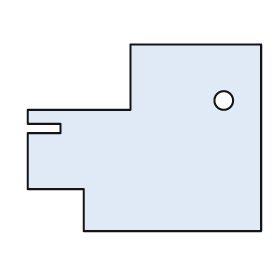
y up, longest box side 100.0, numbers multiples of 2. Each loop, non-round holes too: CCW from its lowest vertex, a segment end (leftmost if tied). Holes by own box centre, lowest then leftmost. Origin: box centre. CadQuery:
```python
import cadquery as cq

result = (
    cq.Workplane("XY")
    .moveTo(-26.0, -40.0)
    .lineTo(50.0, -40.0)
    .lineTo(50.0, 40.0)
    .lineTo(-6.0, 40.0)
    .lineTo(-6.0, 12.0)
    .lineTo(-50.0, 12.0)
    .lineTo(-50.0, 6.0)
    .lineTo(-36.0, 6.0)
    .lineTo(-36.0, 2.0)
    .lineTo(-50.0, 2.0)
    .lineTo(-50.0, -22.0)
    .lineTo(-26.0, -22.0)
    .close()
    .moveTo(34.0, 16.0)
    .circle(4.0)
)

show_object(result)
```